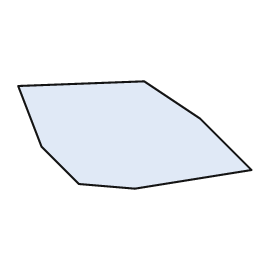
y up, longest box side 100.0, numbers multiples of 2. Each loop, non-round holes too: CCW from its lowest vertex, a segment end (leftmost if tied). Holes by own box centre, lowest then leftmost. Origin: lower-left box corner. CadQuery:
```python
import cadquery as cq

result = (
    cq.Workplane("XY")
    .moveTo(50.0, 0.0)
    .lineTo(100.0, 8.0)
    .lineTo(78.0, 30.0)
    .lineTo(54.0, 46.0)
    .lineTo(0.0, 44.0)
    .lineTo(10.0, 18.0)
    .lineTo(26.0, 2.0)
    .close()
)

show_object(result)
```